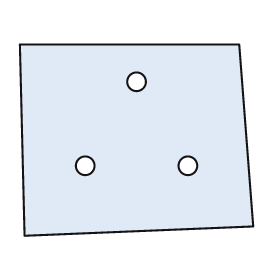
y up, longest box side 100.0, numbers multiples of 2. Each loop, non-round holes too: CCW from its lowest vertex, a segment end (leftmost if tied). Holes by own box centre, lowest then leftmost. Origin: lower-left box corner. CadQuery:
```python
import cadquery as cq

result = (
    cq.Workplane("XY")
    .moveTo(2.0, 0.0)
    .lineTo(100.0, 4.0)
    .lineTo(94.0, 82.0)
    .lineTo(0.0, 82.0)
    .close()
    .moveTo(28.0, 30.0)
    .circle(4.0)
    .moveTo(72.0, 30.0)
    .circle(4.0)
    .moveTo(50.0, 66.0)
    .circle(4.0)
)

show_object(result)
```